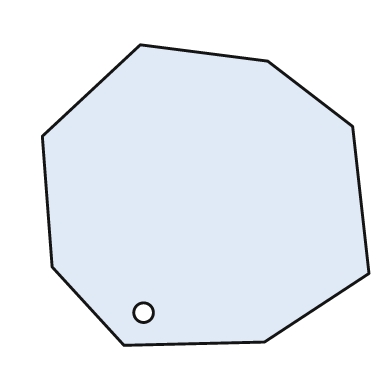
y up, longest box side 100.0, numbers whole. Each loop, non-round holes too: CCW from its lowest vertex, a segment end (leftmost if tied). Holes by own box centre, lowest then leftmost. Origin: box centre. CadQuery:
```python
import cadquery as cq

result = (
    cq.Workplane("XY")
    .moveTo(-25.0, -46.0)
    .lineTo(18.0, -45.0)
    .lineTo(50.0, -24.0)
    .lineTo(45.0, 21.0)
    .lineTo(19.0, 41.0)
    .lineTo(-20.0, 46.0)
    .lineTo(-50.0, 18.0)
    .lineTo(-47.0, -22.0)
    .close()
    .moveTo(-19.0, -36.0)
    .circle(3.0)
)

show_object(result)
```